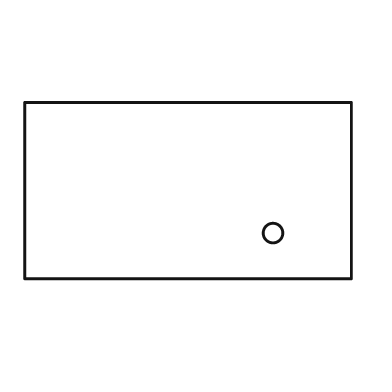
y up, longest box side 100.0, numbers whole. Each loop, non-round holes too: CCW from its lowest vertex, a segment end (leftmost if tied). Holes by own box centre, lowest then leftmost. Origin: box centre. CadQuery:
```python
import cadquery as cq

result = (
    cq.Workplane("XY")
    .moveTo(-50.0, -27.0)
    .lineTo(50.0, -27.0)
    .lineTo(50.0, 27.0)
    .lineTo(-50.0, 27.0)
    .close()
    .moveTo(26.0, -13.0)
    .circle(3.0)
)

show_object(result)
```